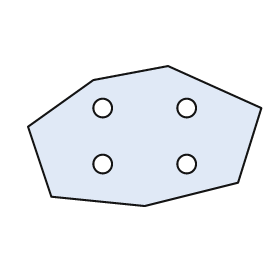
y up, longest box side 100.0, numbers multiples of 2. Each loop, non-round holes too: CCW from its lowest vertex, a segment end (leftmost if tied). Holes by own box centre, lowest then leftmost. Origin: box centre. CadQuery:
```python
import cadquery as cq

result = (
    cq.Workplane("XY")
    .moveTo(0.0, -30.0)
    .lineTo(40.0, -20.0)
    .lineTo(50.0, 12.0)
    .lineTo(10.0, 30.0)
    .lineTo(-22.0, 24.0)
    .lineTo(-50.0, 4.0)
    .lineTo(-40.0, -26.0)
    .close()
    .moveTo(-18.0, -12.0)
    .circle(4.0)
    .moveTo(18.0, -12.0)
    .circle(4.0)
    .moveTo(-18.0, 12.0)
    .circle(4.0)
    .moveTo(18.0, 12.0)
    .circle(4.0)
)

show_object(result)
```